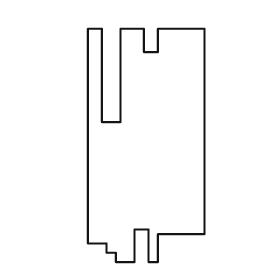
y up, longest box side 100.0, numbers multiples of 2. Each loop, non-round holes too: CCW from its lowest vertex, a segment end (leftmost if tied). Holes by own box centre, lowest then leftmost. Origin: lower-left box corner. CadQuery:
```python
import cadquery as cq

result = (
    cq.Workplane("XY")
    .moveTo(12.0, 0.0)
    .lineTo(20.0, 0.0)
    .lineTo(20.0, 14.0)
    .lineTo(26.0, 14.0)
    .lineTo(26.0, 0.0)
    .lineTo(30.0, 0.0)
    .lineTo(30.0, 12.0)
    .lineTo(50.0, 12.0)
    .lineTo(50.0, 100.0)
    .lineTo(30.0, 100.0)
    .lineTo(30.0, 90.0)
    .lineTo(24.0, 90.0)
    .lineTo(24.0, 100.0)
    .lineTo(14.0, 100.0)
    .lineTo(14.0, 60.0)
    .lineTo(6.0, 60.0)
    .lineTo(6.0, 100.0)
    .lineTo(0.0, 100.0)
    .lineTo(0.0, 8.0)
    .lineTo(8.0, 8.0)
    .lineTo(8.0, 4.0)
    .lineTo(12.0, 4.0)
    .close()
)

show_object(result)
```